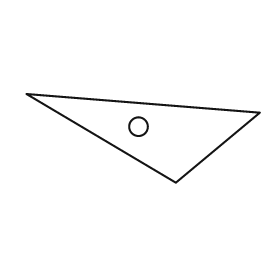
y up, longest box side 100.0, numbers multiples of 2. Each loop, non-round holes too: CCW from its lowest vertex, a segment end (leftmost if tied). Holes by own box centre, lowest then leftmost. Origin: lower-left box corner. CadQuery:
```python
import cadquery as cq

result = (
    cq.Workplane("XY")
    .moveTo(64.0, 0.0)
    .lineTo(100.0, 30.0)
    .lineTo(0.0, 38.0)
    .close()
    .moveTo(48.0, 24.0)
    .circle(4.0)
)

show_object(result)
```